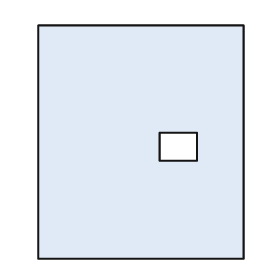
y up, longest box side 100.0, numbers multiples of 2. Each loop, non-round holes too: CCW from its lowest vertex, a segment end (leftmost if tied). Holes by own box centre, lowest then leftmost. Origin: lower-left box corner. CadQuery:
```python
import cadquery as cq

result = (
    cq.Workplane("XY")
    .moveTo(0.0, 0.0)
    .lineTo(88.0, 0.0)
    .lineTo(88.0, 100.0)
    .lineTo(0.0, 100.0)
    .close()
    .moveTo(52.0, 42.0)
    .lineTo(68.0, 42.0)
    .lineTo(68.0, 54.0)
    .lineTo(52.0, 54.0)
    .close()
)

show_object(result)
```